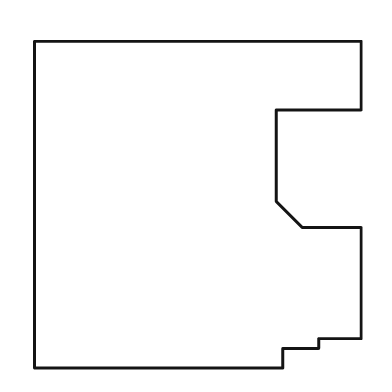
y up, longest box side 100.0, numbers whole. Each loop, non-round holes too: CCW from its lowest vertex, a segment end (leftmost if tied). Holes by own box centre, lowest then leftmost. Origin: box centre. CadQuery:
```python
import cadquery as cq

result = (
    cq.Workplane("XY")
    .moveTo(-50.0, -50.0)
    .lineTo(26.0, -50.0)
    .lineTo(26.0, -44.0)
    .lineTo(37.0, -44.0)
    .lineTo(37.0, -41.0)
    .lineTo(50.0, -41.0)
    .lineTo(50.0, -7.0)
    .lineTo(32.0, -7.0)
    .lineTo(24.0, 1.0)
    .lineTo(24.0, 29.0)
    .lineTo(50.0, 29.0)
    .lineTo(50.0, 50.0)
    .lineTo(-50.0, 50.0)
    .close()
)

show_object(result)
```